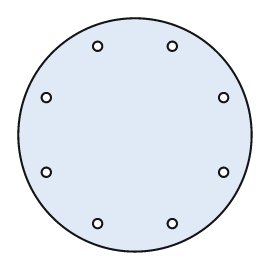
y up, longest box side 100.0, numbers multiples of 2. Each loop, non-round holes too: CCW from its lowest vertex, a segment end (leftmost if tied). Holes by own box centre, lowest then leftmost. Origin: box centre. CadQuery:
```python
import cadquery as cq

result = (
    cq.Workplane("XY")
    .moveTo(0.0, 0.0)
    .circle(50.0)
    .moveTo(-16.0, -38.0)
    .circle(2.0)
    .moveTo(16.0, -38.0)
    .circle(2.0)
    .moveTo(-38.0, -16.0)
    .circle(2.0)
    .moveTo(38.0, -16.0)
    .circle(2.0)
    .moveTo(-38.0, 16.0)
    .circle(2.0)
    .moveTo(38.0, 16.0)
    .circle(2.0)
    .moveTo(-16.0, 38.0)
    .circle(2.0)
    .moveTo(16.0, 38.0)
    .circle(2.0)
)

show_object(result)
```